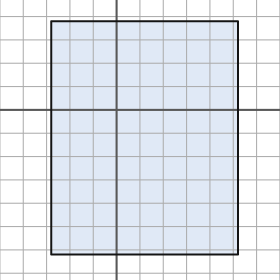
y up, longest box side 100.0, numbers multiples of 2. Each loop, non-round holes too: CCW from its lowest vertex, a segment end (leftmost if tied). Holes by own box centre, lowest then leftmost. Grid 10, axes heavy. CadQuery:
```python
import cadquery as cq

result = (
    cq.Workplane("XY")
    .moveTo(-28.0, -62.0)
    .lineTo(52.0, -62.0)
    .lineTo(52.0, 38.0)
    .lineTo(-28.0, 38.0)
    .close()
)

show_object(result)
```